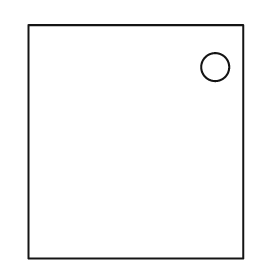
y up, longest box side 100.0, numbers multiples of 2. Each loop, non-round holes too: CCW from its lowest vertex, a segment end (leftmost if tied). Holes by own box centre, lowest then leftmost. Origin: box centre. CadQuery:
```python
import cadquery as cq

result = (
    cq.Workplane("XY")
    .moveTo(-46.0, -50.0)
    .lineTo(46.0, -50.0)
    .lineTo(46.0, 50.0)
    .lineTo(-46.0, 50.0)
    .close()
    .moveTo(34.0, 32.0)
    .circle(6.0)
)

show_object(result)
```